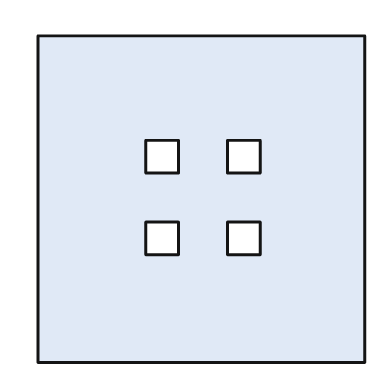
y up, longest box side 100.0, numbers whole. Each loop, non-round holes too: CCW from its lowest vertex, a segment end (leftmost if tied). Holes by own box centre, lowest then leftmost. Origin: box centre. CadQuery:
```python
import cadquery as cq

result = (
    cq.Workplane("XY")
    .moveTo(-50.0, -50.0)
    .lineTo(50.0, -50.0)
    .lineTo(50.0, 50.0)
    .lineTo(-50.0, 50.0)
    .close()
    .moveTo(-17.0, -17.0)
    .lineTo(-7.0, -17.0)
    .lineTo(-7.0, -7.0)
    .lineTo(-17.0, -7.0)
    .close()
    .moveTo(8.0, -17.0)
    .lineTo(18.0, -17.0)
    .lineTo(18.0, -7.0)
    .lineTo(8.0, -7.0)
    .close()
    .moveTo(-17.0, 8.0)
    .lineTo(-7.0, 8.0)
    .lineTo(-7.0, 18.0)
    .lineTo(-17.0, 18.0)
    .close()
    .moveTo(8.0, 8.0)
    .lineTo(18.0, 8.0)
    .lineTo(18.0, 18.0)
    .lineTo(8.0, 18.0)
    .close()
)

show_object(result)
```